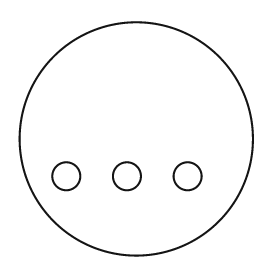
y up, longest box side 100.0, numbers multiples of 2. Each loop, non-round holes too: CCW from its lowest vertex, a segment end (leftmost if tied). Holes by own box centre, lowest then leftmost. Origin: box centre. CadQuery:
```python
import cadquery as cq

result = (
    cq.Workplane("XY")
    .moveTo(0.0, 0.0)
    .circle(50.0)
    .moveTo(-30.0, -16.0)
    .circle(6.0)
    .moveTo(-4.0, -16.0)
    .circle(6.0)
    .moveTo(22.0, -16.0)
    .circle(6.0)
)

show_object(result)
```